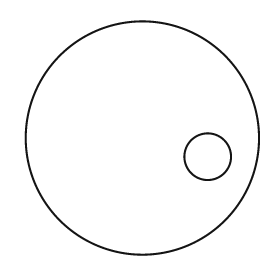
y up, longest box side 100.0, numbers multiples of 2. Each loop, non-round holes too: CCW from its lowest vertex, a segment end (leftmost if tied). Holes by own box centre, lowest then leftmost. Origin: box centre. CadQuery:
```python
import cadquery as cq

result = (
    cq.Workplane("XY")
    .moveTo(0.0, 0.0)
    .circle(50.0)
    .moveTo(28.0, -8.0)
    .circle(10.0)
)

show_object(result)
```